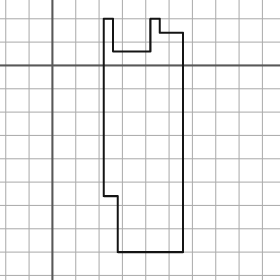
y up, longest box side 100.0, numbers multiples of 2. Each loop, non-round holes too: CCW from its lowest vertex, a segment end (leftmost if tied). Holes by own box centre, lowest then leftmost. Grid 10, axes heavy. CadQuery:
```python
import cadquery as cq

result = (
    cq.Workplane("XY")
    .moveTo(28.0, -80.0)
    .lineTo(56.0, -80.0)
    .lineTo(56.0, 14.0)
    .lineTo(46.0, 14.0)
    .lineTo(46.0, 20.0)
    .lineTo(42.0, 20.0)
    .lineTo(42.0, 6.0)
    .lineTo(26.0, 6.0)
    .lineTo(26.0, 20.0)
    .lineTo(22.0, 20.0)
    .lineTo(22.0, -56.0)
    .lineTo(28.0, -56.0)
    .close()
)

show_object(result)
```